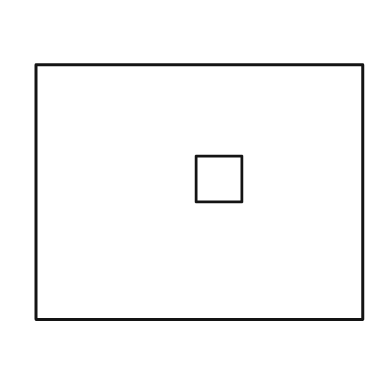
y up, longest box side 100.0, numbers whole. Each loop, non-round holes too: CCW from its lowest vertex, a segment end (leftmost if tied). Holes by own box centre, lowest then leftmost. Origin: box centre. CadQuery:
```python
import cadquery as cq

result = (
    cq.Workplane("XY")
    .moveTo(-50.0, -39.0)
    .lineTo(50.0, -39.0)
    .lineTo(50.0, 39.0)
    .lineTo(-50.0, 39.0)
    .close()
    .moveTo(-1.0, -3.0)
    .lineTo(13.0, -3.0)
    .lineTo(13.0, 11.0)
    .lineTo(-1.0, 11.0)
    .close()
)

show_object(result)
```